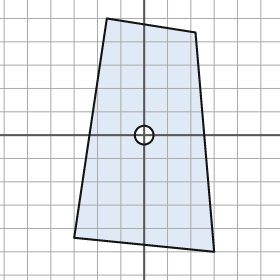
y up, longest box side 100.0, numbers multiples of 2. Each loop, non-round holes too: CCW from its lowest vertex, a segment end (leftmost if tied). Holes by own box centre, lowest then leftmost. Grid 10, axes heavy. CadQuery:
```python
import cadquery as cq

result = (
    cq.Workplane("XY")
    .moveTo(30.0, -50.0)
    .lineTo(22.0, 44.0)
    .lineTo(-16.0, 50.0)
    .lineTo(-30.0, -44.0)
    .close()
    .moveTo(0.0, 0.0)
    .circle(4.0)
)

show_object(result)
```